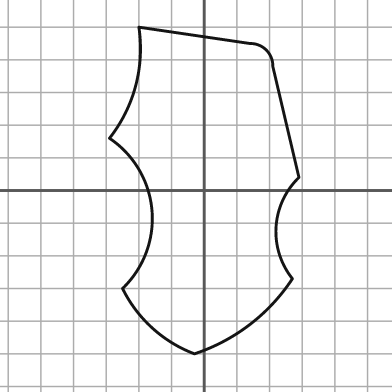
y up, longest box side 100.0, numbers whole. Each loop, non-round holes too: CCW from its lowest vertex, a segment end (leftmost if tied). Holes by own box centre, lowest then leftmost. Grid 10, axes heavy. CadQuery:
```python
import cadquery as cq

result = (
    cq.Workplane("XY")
    .moveTo(-3.0, -50.0)
    .threePointArc((14.0, -41.0), (27.0, -27.0))
    .threePointArc((22.0, -11.0), (29.0, 4.0))
    .lineTo(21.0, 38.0)
    .threePointArc((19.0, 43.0), (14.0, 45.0))
    .lineTo(-20.0, 50.0)
    .threePointArc((-21.0, 32.0), (-29.0, 16.0))
    .threePointArc((-16.0, -6.0), (-25.0, -30.0))
    .threePointArc((-16.0, -42.0), (-3.0, -50.0))
    .close()
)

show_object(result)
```